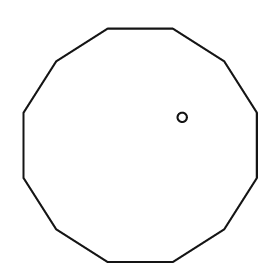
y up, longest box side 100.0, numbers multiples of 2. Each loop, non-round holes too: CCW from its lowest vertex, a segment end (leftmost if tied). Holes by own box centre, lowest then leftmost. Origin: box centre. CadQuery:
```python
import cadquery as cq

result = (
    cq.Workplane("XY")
    .moveTo(-14.0, -50.0)
    .lineTo(14.0, -50.0)
    .lineTo(36.0, -36.0)
    .lineTo(50.0, -14.0)
    .lineTo(50.0, 14.0)
    .lineTo(36.0, 36.0)
    .lineTo(14.0, 50.0)
    .lineTo(-14.0, 50.0)
    .lineTo(-36.0, 36.0)
    .lineTo(-50.0, 14.0)
    .lineTo(-50.0, -14.0)
    .lineTo(-36.0, -36.0)
    .close()
    .moveTo(18.0, 12.0)
    .circle(2.0)
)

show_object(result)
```